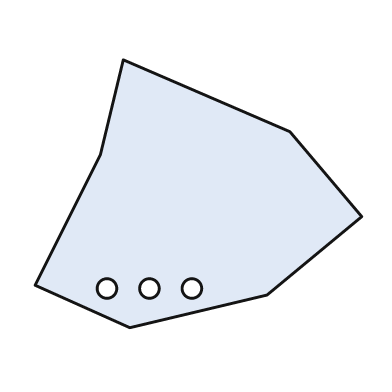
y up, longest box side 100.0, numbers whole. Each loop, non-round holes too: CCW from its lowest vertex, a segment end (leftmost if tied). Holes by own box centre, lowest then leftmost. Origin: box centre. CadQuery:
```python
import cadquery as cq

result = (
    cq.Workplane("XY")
    .moveTo(-21.0, -41.0)
    .lineTo(21.0, -31.0)
    .lineTo(50.0, -7.0)
    .lineTo(28.0, 19.0)
    .lineTo(-23.0, 41.0)
    .lineTo(-30.0, 12.0)
    .lineTo(-50.0, -28.0)
    .close()
    .moveTo(-28.0, -29.0)
    .circle(3.0)
    .moveTo(-15.0, -29.0)
    .circle(3.0)
    .moveTo(-2.0, -29.0)
    .circle(3.0)
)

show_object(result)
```